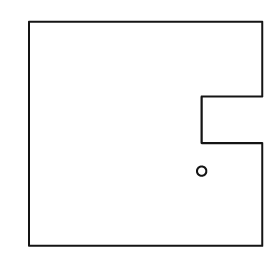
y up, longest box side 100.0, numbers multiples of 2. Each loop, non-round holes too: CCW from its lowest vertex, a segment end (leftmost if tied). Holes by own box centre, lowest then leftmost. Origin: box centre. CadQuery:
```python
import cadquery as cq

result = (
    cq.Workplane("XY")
    .moveTo(-50.0, -48.0)
    .lineTo(50.0, -48.0)
    .lineTo(50.0, -4.0)
    .lineTo(24.0, -4.0)
    .lineTo(24.0, 16.0)
    .lineTo(50.0, 16.0)
    .lineTo(50.0, 48.0)
    .lineTo(-50.0, 48.0)
    .close()
    .moveTo(24.0, -16.0)
    .circle(2.0)
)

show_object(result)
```